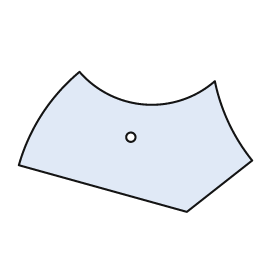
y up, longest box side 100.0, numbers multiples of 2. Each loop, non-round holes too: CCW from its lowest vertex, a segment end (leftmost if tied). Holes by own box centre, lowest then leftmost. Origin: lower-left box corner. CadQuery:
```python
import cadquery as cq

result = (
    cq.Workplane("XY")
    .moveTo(72.0, 0.0)
    .lineTo(100.0, 22.0)
    .threePointArc((90.0, 38.0), (84.0, 56.0))
    .threePointArc((54.0, 46.0), (26.0, 60.0))
    .threePointArc((10.0, 42.0), (0.0, 20.0))
    .close()
    .moveTo(48.0, 32.0)
    .circle(2.0)
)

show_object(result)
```